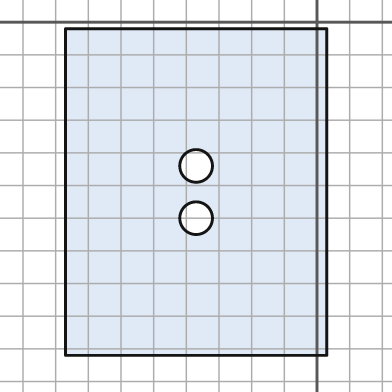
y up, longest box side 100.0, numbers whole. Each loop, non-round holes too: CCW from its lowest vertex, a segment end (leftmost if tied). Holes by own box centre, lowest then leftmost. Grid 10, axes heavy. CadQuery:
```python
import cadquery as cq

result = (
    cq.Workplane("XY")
    .moveTo(-77.0, -102.0)
    .lineTo(3.0, -102.0)
    .lineTo(3.0, -2.0)
    .lineTo(-77.0, -2.0)
    .close()
    .moveTo(-37.0, -60.0)
    .circle(5.0)
    .moveTo(-37.0, -44.0)
    .circle(5.0)
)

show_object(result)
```